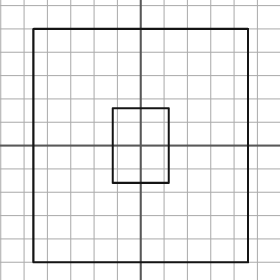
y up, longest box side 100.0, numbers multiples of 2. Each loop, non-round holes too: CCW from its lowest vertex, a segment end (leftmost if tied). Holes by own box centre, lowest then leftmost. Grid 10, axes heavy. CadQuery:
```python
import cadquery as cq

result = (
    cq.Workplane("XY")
    .moveTo(-46.0, -50.0)
    .lineTo(46.0, -50.0)
    .lineTo(46.0, 50.0)
    .lineTo(-46.0, 50.0)
    .close()
    .moveTo(-12.0, -16.0)
    .lineTo(12.0, -16.0)
    .lineTo(12.0, 16.0)
    .lineTo(-12.0, 16.0)
    .close()
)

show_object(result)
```